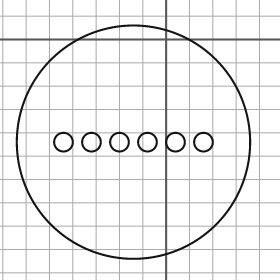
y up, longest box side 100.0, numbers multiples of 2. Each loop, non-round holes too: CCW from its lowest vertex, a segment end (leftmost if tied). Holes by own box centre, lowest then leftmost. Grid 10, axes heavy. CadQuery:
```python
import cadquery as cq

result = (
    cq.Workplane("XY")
    .moveTo(-14.0, -44.0)
    .circle(50.0)
    .moveTo(-44.0, -44.0)
    .circle(4.0)
    .moveTo(-32.0, -44.0)
    .circle(4.0)
    .moveTo(-20.0, -44.0)
    .circle(4.0)
    .moveTo(-8.0, -44.0)
    .circle(4.0)
    .moveTo(4.0, -44.0)
    .circle(4.0)
    .moveTo(16.0, -44.0)
    .circle(4.0)
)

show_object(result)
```